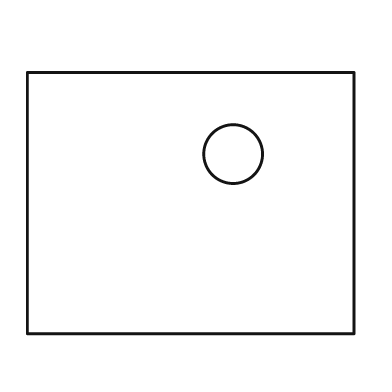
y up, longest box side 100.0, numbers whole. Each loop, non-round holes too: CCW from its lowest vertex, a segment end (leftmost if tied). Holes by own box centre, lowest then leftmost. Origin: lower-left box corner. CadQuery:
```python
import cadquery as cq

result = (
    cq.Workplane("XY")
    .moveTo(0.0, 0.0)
    .lineTo(100.0, 0.0)
    .lineTo(100.0, 80.0)
    .lineTo(0.0, 80.0)
    .close()
    .moveTo(63.0, 55.0)
    .circle(9.0)
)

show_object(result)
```